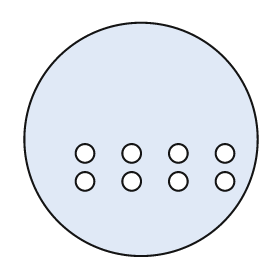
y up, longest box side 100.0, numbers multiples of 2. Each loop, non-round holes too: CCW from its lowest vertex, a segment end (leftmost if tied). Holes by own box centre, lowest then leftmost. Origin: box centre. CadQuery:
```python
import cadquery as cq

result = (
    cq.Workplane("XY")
    .moveTo(0.0, 0.0)
    .circle(50.0)
    .moveTo(-24.0, -18.0)
    .circle(4.0)
    .moveTo(-4.0, -18.0)
    .circle(4.0)
    .moveTo(16.0, -18.0)
    .circle(4.0)
    .moveTo(36.0, -18.0)
    .circle(4.0)
    .moveTo(-24.0, -6.0)
    .circle(4.0)
    .moveTo(-4.0, -6.0)
    .circle(4.0)
    .moveTo(16.0, -6.0)
    .circle(4.0)
    .moveTo(36.0, -6.0)
    .circle(4.0)
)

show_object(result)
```